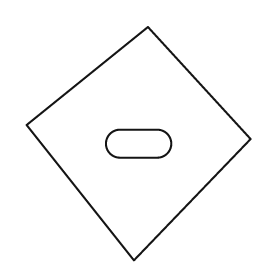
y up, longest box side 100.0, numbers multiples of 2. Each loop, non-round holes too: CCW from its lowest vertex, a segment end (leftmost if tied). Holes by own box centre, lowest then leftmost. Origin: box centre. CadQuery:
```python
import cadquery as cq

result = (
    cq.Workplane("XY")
    .moveTo(-2.0, -50.0)
    .lineTo(48.0, 2.0)
    .lineTo(4.0, 50.0)
    .lineTo(-48.0, 8.0)
    .close()
    .moveTo(-8.0, -6.0)
    .lineTo(8.0, -6.0)
    .threePointArc((14.0, 0.0), (8.0, 6.0))
    .lineTo(-8.0, 6.0)
    .threePointArc((-14.0, 0.0), (-8.0, -6.0))
    .close()
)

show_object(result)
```